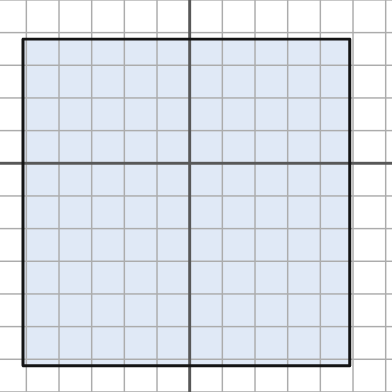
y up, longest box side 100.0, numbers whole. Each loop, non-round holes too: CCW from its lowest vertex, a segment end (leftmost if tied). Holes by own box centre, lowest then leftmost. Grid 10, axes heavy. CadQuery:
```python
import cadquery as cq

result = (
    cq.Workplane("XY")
    .moveTo(-51.0, -62.0)
    .lineTo(49.0, -62.0)
    .lineTo(49.0, 38.0)
    .lineTo(-51.0, 38.0)
    .close()
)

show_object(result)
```